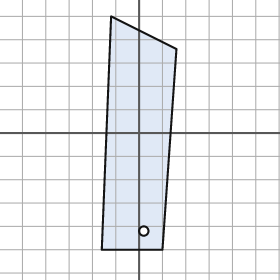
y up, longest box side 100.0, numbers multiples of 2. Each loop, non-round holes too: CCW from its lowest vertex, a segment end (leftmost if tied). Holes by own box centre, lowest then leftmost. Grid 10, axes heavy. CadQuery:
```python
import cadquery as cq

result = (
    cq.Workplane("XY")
    .moveTo(-16.0, -50.0)
    .lineTo(10.0, -50.0)
    .lineTo(16.0, 36.0)
    .lineTo(-12.0, 50.0)
    .close()
    .moveTo(2.0, -42.0)
    .circle(2.0)
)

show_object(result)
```